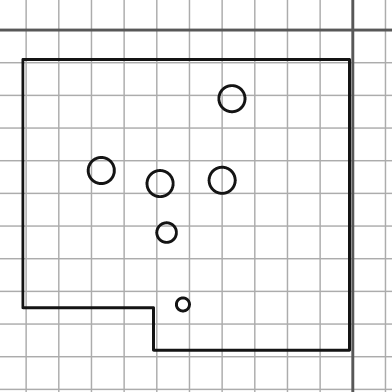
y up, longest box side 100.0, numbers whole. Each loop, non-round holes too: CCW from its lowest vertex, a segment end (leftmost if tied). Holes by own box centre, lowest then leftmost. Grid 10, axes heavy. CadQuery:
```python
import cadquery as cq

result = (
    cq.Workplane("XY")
    .moveTo(-61.0, -98.0)
    .lineTo(-1.0, -98.0)
    .lineTo(-1.0, -9.0)
    .lineTo(-101.0, -9.0)
    .lineTo(-101.0, -85.0)
    .lineTo(-61.0, -85.0)
    .close()
    .moveTo(-52.0, -84.0)
    .circle(2.0)
    .moveTo(-57.0, -62.0)
    .circle(3.0)
    .moveTo(-59.0, -47.0)
    .circle(4.0)
    .moveTo(-40.0, -46.0)
    .circle(4.0)
    .moveTo(-77.0, -43.0)
    .circle(4.0)
    .moveTo(-37.0, -21.0)
    .circle(4.0)
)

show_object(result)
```